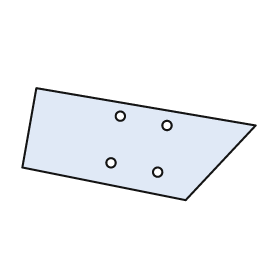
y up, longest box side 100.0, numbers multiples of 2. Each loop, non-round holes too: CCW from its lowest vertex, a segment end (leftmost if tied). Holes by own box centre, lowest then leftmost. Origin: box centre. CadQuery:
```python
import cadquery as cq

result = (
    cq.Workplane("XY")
    .moveTo(20.0, -24.0)
    .lineTo(50.0, 8.0)
    .lineTo(-44.0, 24.0)
    .lineTo(-50.0, -10.0)
    .close()
    .moveTo(8.0, -12.0)
    .circle(2.0)
    .moveTo(-12.0, -8.0)
    .circle(2.0)
    .moveTo(12.0, 8.0)
    .circle(2.0)
    .moveTo(-8.0, 12.0)
    .circle(2.0)
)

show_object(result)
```